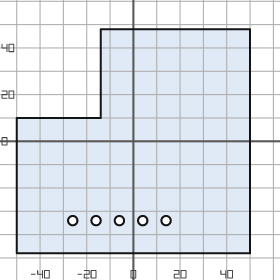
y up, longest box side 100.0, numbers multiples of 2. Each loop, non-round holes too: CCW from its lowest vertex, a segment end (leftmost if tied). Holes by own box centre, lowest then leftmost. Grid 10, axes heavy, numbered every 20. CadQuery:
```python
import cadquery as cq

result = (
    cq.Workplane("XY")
    .moveTo(-50.0, -48.0)
    .lineTo(50.0, -48.0)
    .lineTo(50.0, 48.0)
    .lineTo(-14.0, 48.0)
    .lineTo(-14.0, 10.0)
    .lineTo(-50.0, 10.0)
    .close()
    .moveTo(-26.0, -34.0)
    .circle(2.0)
    .moveTo(-16.0, -34.0)
    .circle(2.0)
    .moveTo(-6.0, -34.0)
    .circle(2.0)
    .moveTo(4.0, -34.0)
    .circle(2.0)
    .moveTo(14.0, -34.0)
    .circle(2.0)
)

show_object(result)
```